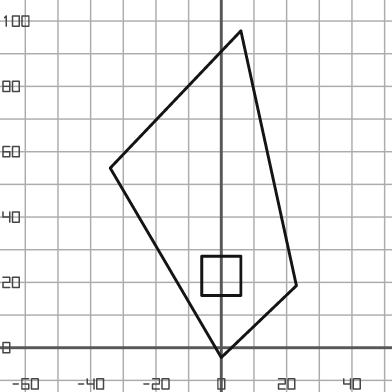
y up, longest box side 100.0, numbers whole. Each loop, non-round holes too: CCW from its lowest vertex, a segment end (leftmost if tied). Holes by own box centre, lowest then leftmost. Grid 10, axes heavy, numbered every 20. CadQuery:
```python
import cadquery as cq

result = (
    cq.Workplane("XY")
    .moveTo(0.0, -3.0)
    .lineTo(23.0, 19.0)
    .lineTo(6.0, 97.0)
    .lineTo(-34.0, 55.0)
    .close()
    .moveTo(-6.0, 16.0)
    .lineTo(6.0, 16.0)
    .lineTo(6.0, 28.0)
    .lineTo(-6.0, 28.0)
    .close()
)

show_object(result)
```